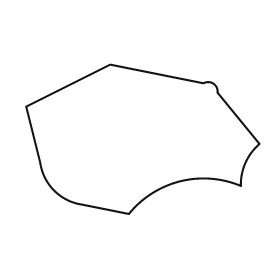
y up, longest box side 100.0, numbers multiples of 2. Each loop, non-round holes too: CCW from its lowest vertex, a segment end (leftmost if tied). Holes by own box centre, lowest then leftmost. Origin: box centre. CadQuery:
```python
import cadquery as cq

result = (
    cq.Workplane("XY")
    .moveTo(-6.0, -32.0)
    .threePointArc((16.0, -18.0), (42.0, -20.0))
    .threePointArc((44.0, -10.0), (50.0, -2.0))
    .lineTo(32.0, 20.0)
    .threePointArc((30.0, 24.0), (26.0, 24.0))
    .lineTo(-14.0, 32.0)
    .lineTo(-50.0, 14.0)
    .lineTo(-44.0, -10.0)
    .threePointArc((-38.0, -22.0), (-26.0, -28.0))
    .close()
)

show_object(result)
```